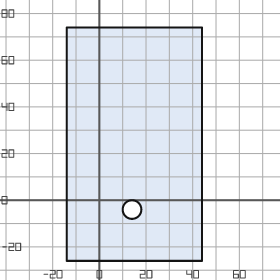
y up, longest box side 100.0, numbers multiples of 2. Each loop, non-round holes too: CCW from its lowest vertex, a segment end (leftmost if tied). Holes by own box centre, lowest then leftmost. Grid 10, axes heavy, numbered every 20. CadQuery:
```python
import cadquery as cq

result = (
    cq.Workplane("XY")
    .moveTo(-14.0, -26.0)
    .lineTo(44.0, -26.0)
    .lineTo(44.0, 74.0)
    .lineTo(-14.0, 74.0)
    .close()
    .moveTo(14.0, -4.0)
    .circle(4.0)
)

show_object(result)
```